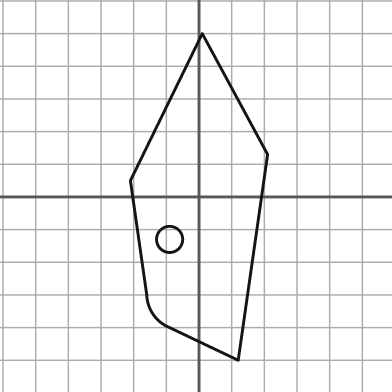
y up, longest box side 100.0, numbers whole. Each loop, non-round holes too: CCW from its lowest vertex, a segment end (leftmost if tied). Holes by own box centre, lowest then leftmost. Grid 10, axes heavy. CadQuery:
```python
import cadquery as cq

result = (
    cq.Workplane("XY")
    .moveTo(12.0, -50.0)
    .lineTo(21.0, 13.0)
    .lineTo(1.0, 50.0)
    .lineTo(-21.0, 5.0)
    .lineTo(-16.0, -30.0)
    .threePointArc((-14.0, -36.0), (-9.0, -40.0))
    .close()
    .moveTo(-9.0, -13.0)
    .circle(4.0)
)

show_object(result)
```